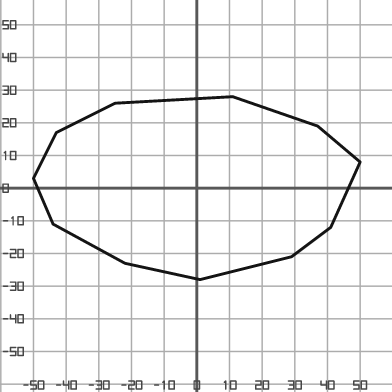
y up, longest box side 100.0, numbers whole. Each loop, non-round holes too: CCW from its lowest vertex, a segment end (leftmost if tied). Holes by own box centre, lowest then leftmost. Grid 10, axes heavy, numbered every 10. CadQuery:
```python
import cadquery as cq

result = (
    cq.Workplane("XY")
    .moveTo(1.0, -28.0)
    .lineTo(29.0, -21.0)
    .lineTo(41.0, -12.0)
    .lineTo(50.0, 8.0)
    .lineTo(37.0, 19.0)
    .lineTo(11.0, 28.0)
    .lineTo(-25.0, 26.0)
    .lineTo(-43.0, 17.0)
    .lineTo(-50.0, 3.0)
    .lineTo(-44.0, -11.0)
    .lineTo(-22.0, -23.0)
    .close()
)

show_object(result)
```